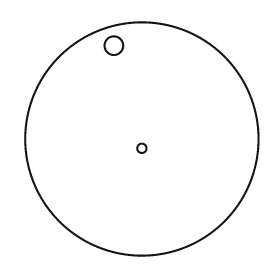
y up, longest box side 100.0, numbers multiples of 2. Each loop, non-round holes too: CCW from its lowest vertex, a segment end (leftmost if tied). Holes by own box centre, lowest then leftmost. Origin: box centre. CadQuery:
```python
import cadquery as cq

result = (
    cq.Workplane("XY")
    .moveTo(0.0, 0.0)
    .circle(50.0)
    .moveTo(0.0, -4.0)
    .circle(2.0)
    .moveTo(-12.0, 40.0)
    .circle(4.0)
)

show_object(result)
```